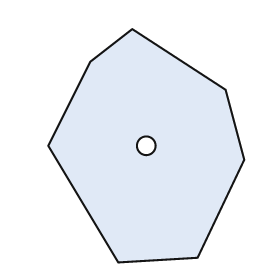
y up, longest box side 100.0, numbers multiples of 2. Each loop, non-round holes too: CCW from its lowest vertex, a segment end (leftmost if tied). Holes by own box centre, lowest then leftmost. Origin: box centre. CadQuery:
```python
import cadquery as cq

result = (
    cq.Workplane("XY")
    .moveTo(-12.0, -50.0)
    .lineTo(22.0, -48.0)
    .lineTo(42.0, -6.0)
    .lineTo(34.0, 24.0)
    .lineTo(-6.0, 50.0)
    .lineTo(-24.0, 36.0)
    .lineTo(-42.0, 0.0)
    .close()
    .moveTo(0.0, 0.0)
    .circle(4.0)
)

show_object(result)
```